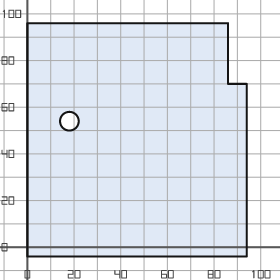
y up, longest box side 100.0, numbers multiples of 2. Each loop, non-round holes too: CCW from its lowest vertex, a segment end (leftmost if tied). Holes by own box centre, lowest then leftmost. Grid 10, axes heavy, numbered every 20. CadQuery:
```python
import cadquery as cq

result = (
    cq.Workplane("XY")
    .moveTo(0.0, -4.0)
    .lineTo(94.0, -4.0)
    .lineTo(94.0, 70.0)
    .lineTo(86.0, 70.0)
    .lineTo(86.0, 96.0)
    .lineTo(0.0, 96.0)
    .close()
    .moveTo(18.0, 54.0)
    .circle(4.0)
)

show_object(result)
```